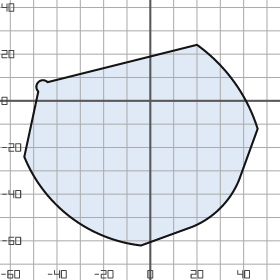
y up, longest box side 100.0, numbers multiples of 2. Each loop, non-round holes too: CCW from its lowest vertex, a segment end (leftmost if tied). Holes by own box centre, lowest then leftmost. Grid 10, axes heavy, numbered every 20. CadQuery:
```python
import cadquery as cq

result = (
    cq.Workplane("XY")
    .moveTo(-4.0, -62.0)
    .lineTo(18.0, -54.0)
    .threePointArc((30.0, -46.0), (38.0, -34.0))
    .lineTo(46.0, -12.0)
    .threePointArc((36.0, 8.0), (20.0, 24.0))
    .lineTo(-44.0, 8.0)
    .threePointArc((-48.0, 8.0), (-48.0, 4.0))
    .lineTo(-54.0, -24.0)
    .threePointArc((-34.0, -50.0), (-4.0, -62.0))
    .close()
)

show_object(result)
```